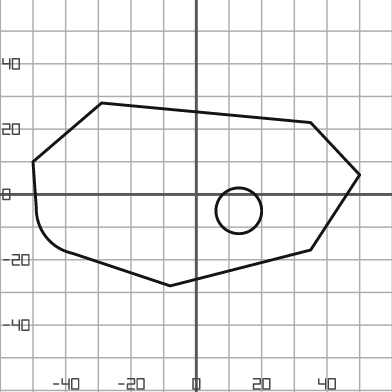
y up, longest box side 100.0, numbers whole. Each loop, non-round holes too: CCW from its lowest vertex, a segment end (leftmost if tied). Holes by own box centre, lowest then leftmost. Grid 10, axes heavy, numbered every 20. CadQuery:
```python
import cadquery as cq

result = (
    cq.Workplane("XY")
    .moveTo(-8.0, -28.0)
    .lineTo(35.0, -17.0)
    .lineTo(50.0, 6.0)
    .lineTo(35.0, 22.0)
    .lineTo(-29.0, 28.0)
    .lineTo(-50.0, 10.0)
    .lineTo(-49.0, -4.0)
    .threePointArc((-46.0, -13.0), (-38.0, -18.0))
    .close()
    .moveTo(13.0, -5.0)
    .circle(7.0)
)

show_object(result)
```